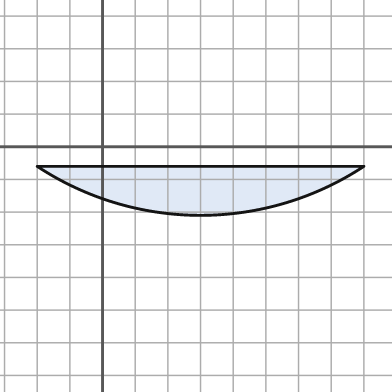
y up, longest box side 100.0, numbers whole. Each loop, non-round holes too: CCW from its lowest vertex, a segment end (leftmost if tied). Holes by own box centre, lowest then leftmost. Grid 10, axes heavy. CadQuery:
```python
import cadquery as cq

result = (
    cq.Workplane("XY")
    .moveTo(-20.0, -6.0)
    .threePointArc((30.0, -21.0), (80.0, -6.0))
    .close()
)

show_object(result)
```